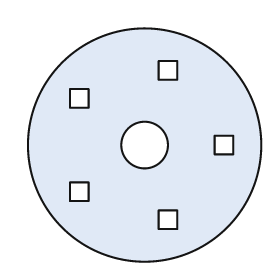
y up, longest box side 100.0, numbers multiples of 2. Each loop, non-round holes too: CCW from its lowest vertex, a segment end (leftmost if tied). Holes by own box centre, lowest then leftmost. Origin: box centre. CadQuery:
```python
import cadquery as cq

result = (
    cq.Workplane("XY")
    .moveTo(0.0, 0.0)
    .circle(50.0)
    .moveTo(6.0, -36.0)
    .lineTo(14.0, -36.0)
    .lineTo(14.0, -28.0)
    .lineTo(6.0, -28.0)
    .close()
    .moveTo(-32.0, -24.0)
    .lineTo(-24.0, -24.0)
    .lineTo(-24.0, -16.0)
    .lineTo(-32.0, -16.0)
    .close()
    .moveTo(0.0, 0.0)
    .circle(10.0)
    .moveTo(30.0, -4.0)
    .lineTo(38.0, -4.0)
    .lineTo(38.0, 4.0)
    .lineTo(30.0, 4.0)
    .close()
    .moveTo(-32.0, 16.0)
    .lineTo(-24.0, 16.0)
    .lineTo(-24.0, 24.0)
    .lineTo(-32.0, 24.0)
    .close()
    .moveTo(6.0, 28.0)
    .lineTo(14.0, 28.0)
    .lineTo(14.0, 36.0)
    .lineTo(6.0, 36.0)
    .close()
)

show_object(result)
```